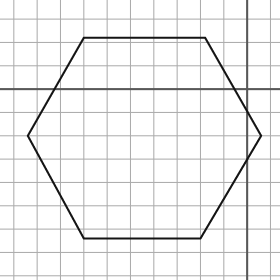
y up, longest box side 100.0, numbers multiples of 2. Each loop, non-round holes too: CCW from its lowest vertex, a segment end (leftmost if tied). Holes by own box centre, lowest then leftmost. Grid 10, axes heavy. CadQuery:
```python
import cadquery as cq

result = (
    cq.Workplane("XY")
    .moveTo(-70.0, -64.0)
    .lineTo(-20.0, -64.0)
    .lineTo(6.0, -20.0)
    .lineTo(-18.0, 22.0)
    .lineTo(-70.0, 22.0)
    .lineTo(-94.0, -20.0)
    .close()
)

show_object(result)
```